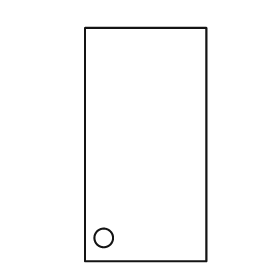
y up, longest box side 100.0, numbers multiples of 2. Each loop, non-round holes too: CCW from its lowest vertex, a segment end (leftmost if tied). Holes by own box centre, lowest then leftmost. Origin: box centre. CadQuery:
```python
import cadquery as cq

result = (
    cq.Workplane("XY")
    .moveTo(-26.0, -50.0)
    .lineTo(26.0, -50.0)
    .lineTo(26.0, 50.0)
    .lineTo(-26.0, 50.0)
    .close()
    .moveTo(-18.0, -40.0)
    .circle(4.0)
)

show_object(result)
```